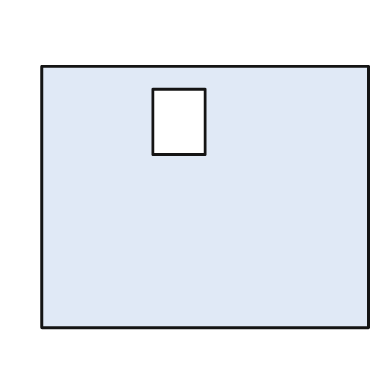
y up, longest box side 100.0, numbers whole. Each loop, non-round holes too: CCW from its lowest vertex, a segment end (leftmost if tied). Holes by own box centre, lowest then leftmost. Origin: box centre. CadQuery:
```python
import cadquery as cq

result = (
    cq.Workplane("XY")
    .moveTo(-50.0, -40.0)
    .lineTo(50.0, -40.0)
    .lineTo(50.0, 40.0)
    .lineTo(-50.0, 40.0)
    .close()
    .moveTo(-16.0, 13.0)
    .lineTo(0.0, 13.0)
    .lineTo(0.0, 33.0)
    .lineTo(-16.0, 33.0)
    .close()
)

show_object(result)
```